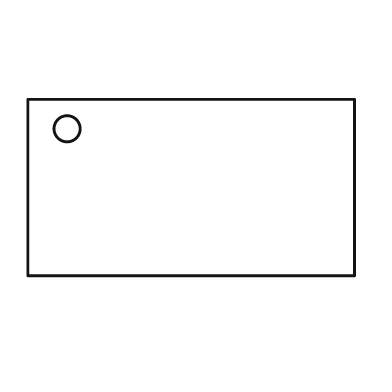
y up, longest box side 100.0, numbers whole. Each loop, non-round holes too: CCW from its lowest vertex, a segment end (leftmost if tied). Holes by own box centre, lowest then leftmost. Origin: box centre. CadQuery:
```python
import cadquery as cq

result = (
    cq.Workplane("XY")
    .moveTo(-50.0, -27.0)
    .lineTo(50.0, -27.0)
    .lineTo(50.0, 27.0)
    .lineTo(-50.0, 27.0)
    .close()
    .moveTo(-38.0, 18.0)
    .circle(4.0)
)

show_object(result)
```